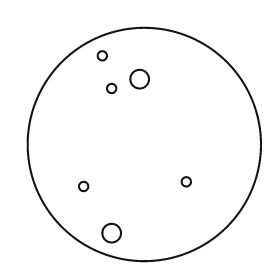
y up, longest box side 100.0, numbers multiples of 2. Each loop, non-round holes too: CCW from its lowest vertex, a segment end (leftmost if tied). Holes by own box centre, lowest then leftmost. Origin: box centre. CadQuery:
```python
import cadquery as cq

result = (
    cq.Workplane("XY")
    .moveTo(0.0, 0.0)
    .circle(50.0)
    .moveTo(-14.0, -38.0)
    .circle(4.0)
    .moveTo(-26.0, -18.0)
    .circle(2.0)
    .moveTo(18.0, -16.0)
    .circle(2.0)
    .moveTo(-14.0, 24.0)
    .circle(2.0)
    .moveTo(-2.0, 28.0)
    .circle(4.0)
    .moveTo(-18.0, 38.0)
    .circle(2.0)
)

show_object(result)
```